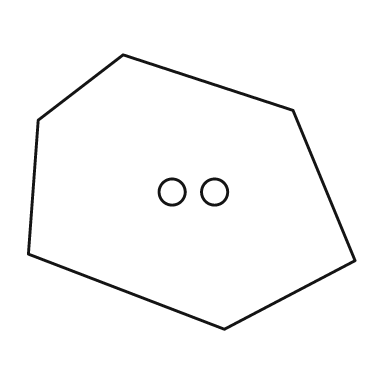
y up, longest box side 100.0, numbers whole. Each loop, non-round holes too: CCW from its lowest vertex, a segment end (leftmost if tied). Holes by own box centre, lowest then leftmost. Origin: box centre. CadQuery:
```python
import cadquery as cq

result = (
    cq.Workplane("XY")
    .moveTo(10.0, -42.0)
    .lineTo(50.0, -21.0)
    .lineTo(31.0, 25.0)
    .lineTo(-21.0, 42.0)
    .lineTo(-47.0, 22.0)
    .lineTo(-50.0, -19.0)
    .close()
    .moveTo(-6.0, 0.0)
    .circle(4.0)
    .moveTo(7.0, 0.0)
    .circle(4.0)
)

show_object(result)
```